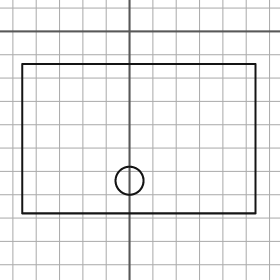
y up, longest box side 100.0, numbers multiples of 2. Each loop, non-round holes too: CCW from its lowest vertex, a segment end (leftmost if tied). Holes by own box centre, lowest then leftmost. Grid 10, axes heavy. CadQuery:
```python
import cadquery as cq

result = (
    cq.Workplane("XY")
    .moveTo(-46.0, -78.0)
    .lineTo(54.0, -78.0)
    .lineTo(54.0, -14.0)
    .lineTo(-46.0, -14.0)
    .close()
    .moveTo(0.0, -64.0)
    .circle(6.0)
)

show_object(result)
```